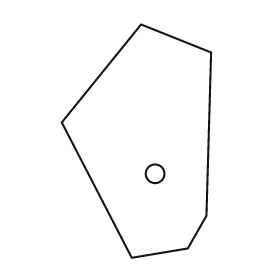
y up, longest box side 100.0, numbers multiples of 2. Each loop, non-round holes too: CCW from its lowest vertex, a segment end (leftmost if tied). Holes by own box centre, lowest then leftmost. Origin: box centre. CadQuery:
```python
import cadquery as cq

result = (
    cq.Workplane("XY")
    .moveTo(-2.0, -50.0)
    .lineTo(22.0, -46.0)
    .lineTo(30.0, -32.0)
    .lineTo(32.0, 38.0)
    .lineTo(2.0, 50.0)
    .lineTo(-32.0, 8.0)
    .close()
    .moveTo(8.0, -14.0)
    .circle(4.0)
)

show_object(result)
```